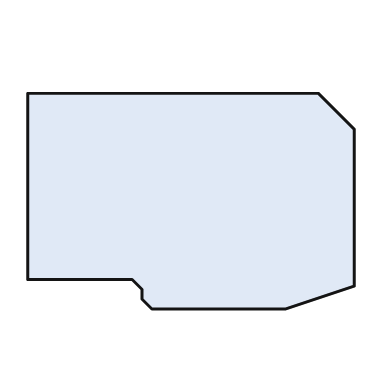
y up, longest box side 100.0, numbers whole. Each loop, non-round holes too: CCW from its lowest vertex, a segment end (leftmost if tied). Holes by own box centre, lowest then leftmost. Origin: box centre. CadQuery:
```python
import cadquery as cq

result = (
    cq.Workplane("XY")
    .moveTo(-12.0, -33.0)
    .lineTo(29.0, -33.0)
    .lineTo(50.0, -26.0)
    .lineTo(50.0, 22.0)
    .lineTo(39.0, 33.0)
    .lineTo(-50.0, 33.0)
    .lineTo(-50.0, -24.0)
    .lineTo(-18.0, -24.0)
    .lineTo(-15.0, -27.0)
    .lineTo(-15.0, -30.0)
    .close()
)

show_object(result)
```